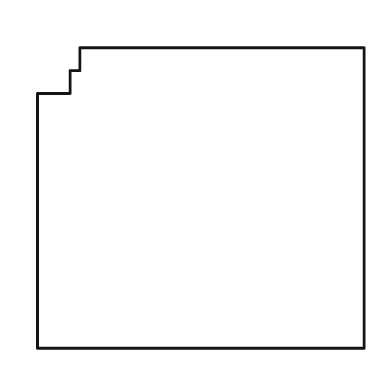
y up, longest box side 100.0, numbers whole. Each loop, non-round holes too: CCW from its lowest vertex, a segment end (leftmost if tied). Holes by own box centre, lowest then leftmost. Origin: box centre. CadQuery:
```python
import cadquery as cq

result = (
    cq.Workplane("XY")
    .moveTo(-50.0, -46.0)
    .lineTo(50.0, -46.0)
    .lineTo(50.0, 46.0)
    .lineTo(-37.0, 46.0)
    .lineTo(-37.0, 39.0)
    .lineTo(-40.0, 39.0)
    .lineTo(-40.0, 32.0)
    .lineTo(-50.0, 32.0)
    .close()
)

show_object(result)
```